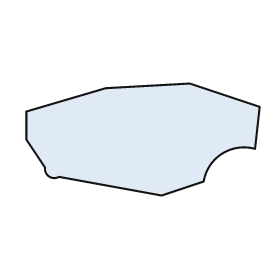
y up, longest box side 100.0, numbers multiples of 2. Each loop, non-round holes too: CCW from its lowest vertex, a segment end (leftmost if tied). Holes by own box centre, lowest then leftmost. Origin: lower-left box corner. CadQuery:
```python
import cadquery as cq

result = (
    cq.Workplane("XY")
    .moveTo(58.0, 0.0)
    .lineTo(76.0, 6.0)
    .threePointArc((84.0, 18.0), (98.0, 20.0))
    .lineTo(100.0, 38.0)
    .lineTo(70.0, 48.0)
    .lineTo(34.0, 46.0)
    .lineTo(0.0, 36.0)
    .lineTo(0.0, 24.0)
    .lineTo(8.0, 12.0)
    .threePointArc((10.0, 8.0), (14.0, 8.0))
    .close()
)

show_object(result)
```